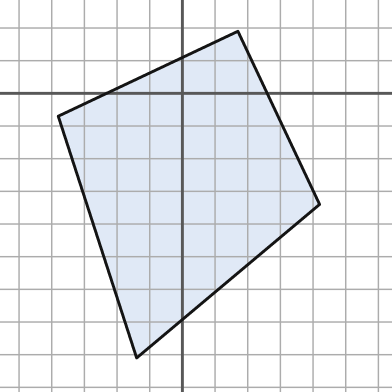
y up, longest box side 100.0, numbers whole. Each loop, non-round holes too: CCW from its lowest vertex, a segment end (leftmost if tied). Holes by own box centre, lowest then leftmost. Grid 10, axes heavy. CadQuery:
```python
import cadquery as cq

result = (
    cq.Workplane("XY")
    .moveTo(-14.0, -81.0)
    .lineTo(42.0, -34.0)
    .lineTo(17.0, 19.0)
    .lineTo(-38.0, -7.0)
    .close()
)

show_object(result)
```